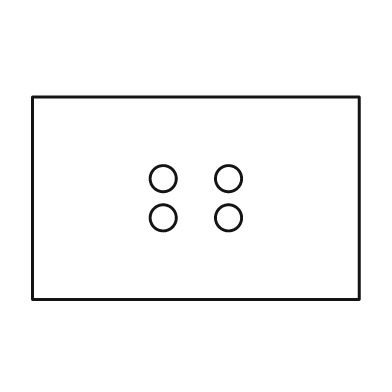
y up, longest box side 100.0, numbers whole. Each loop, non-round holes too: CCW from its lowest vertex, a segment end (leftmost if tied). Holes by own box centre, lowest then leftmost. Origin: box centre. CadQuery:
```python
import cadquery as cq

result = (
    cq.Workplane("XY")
    .moveTo(-50.0, -31.0)
    .lineTo(50.0, -31.0)
    .lineTo(50.0, 31.0)
    .lineTo(-50.0, 31.0)
    .close()
    .moveTo(-10.0, -6.0)
    .circle(4.0)
    .moveTo(10.0, -6.0)
    .circle(4.0)
    .moveTo(-10.0, 6.0)
    .circle(4.0)
    .moveTo(10.0, 6.0)
    .circle(4.0)
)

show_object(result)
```